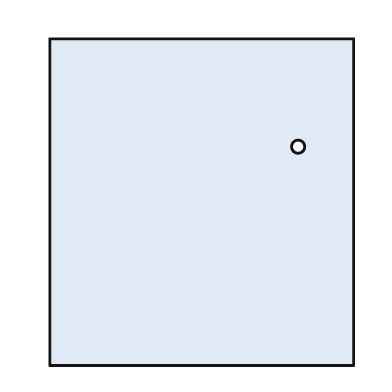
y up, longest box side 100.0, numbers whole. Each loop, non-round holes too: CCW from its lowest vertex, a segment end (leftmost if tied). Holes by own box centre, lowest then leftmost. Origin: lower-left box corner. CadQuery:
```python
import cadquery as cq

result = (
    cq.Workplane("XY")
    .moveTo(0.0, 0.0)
    .lineTo(93.0, 0.0)
    .lineTo(93.0, 100.0)
    .lineTo(0.0, 100.0)
    .close()
    .moveTo(76.0, 67.0)
    .circle(2.0)
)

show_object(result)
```